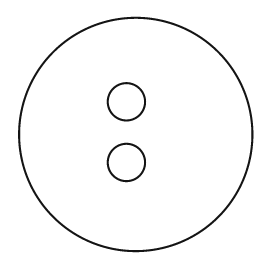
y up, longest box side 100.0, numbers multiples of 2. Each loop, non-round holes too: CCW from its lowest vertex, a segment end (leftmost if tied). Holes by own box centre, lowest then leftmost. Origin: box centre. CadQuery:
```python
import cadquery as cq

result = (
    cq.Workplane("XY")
    .moveTo(0.0, 0.0)
    .circle(50.0)
    .moveTo(-4.0, -12.0)
    .circle(8.0)
    .moveTo(-4.0, 14.0)
    .circle(8.0)
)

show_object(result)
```